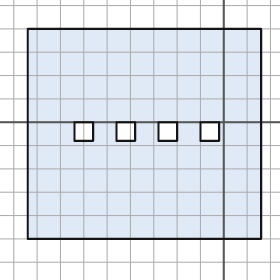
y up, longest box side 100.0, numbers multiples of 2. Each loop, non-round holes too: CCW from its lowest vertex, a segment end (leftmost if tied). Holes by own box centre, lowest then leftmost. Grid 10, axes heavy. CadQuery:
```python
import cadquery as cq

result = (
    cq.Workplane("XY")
    .moveTo(-84.0, -50.0)
    .lineTo(16.0, -50.0)
    .lineTo(16.0, 40.0)
    .lineTo(-84.0, 40.0)
    .close()
    .moveTo(-64.0, -8.0)
    .lineTo(-56.0, -8.0)
    .lineTo(-56.0, 0.0)
    .lineTo(-64.0, 0.0)
    .close()
    .moveTo(-46.0, -8.0)
    .lineTo(-38.0, -8.0)
    .lineTo(-38.0, 0.0)
    .lineTo(-46.0, 0.0)
    .close()
    .moveTo(-28.0, -8.0)
    .lineTo(-20.0, -8.0)
    .lineTo(-20.0, 0.0)
    .lineTo(-28.0, 0.0)
    .close()
    .moveTo(-10.0, -8.0)
    .lineTo(-2.0, -8.0)
    .lineTo(-2.0, 0.0)
    .lineTo(-10.0, 0.0)
    .close()
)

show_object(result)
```